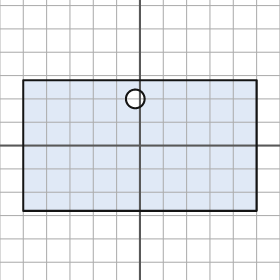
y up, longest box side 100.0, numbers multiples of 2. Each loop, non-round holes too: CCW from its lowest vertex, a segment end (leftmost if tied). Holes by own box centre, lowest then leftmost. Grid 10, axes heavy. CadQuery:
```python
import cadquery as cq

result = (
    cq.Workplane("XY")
    .moveTo(-50.0, -28.0)
    .lineTo(50.0, -28.0)
    .lineTo(50.0, 28.0)
    .lineTo(-50.0, 28.0)
    .close()
    .moveTo(-2.0, 20.0)
    .circle(4.0)
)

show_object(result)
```